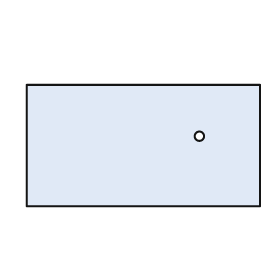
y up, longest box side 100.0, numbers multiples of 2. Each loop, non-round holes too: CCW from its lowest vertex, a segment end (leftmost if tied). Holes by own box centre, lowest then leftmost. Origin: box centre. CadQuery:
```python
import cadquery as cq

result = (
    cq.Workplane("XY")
    .moveTo(-50.0, -26.0)
    .lineTo(50.0, -26.0)
    .lineTo(50.0, 26.0)
    .lineTo(-50.0, 26.0)
    .close()
    .moveTo(24.0, 4.0)
    .circle(2.0)
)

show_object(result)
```